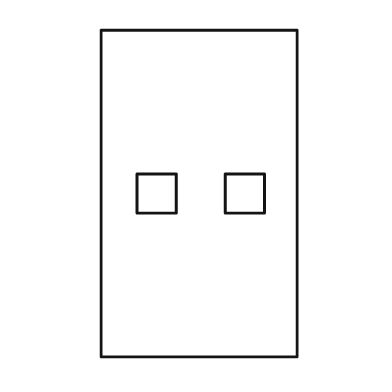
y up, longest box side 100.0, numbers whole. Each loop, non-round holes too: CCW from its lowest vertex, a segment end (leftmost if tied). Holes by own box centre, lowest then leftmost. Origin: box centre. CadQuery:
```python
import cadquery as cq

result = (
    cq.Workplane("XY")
    .moveTo(-30.0, -50.0)
    .lineTo(30.0, -50.0)
    .lineTo(30.0, 50.0)
    .lineTo(-30.0, 50.0)
    .close()
    .moveTo(-19.0, -6.0)
    .lineTo(-7.0, -6.0)
    .lineTo(-7.0, 6.0)
    .lineTo(-19.0, 6.0)
    .close()
    .moveTo(8.0, -6.0)
    .lineTo(20.0, -6.0)
    .lineTo(20.0, 6.0)
    .lineTo(8.0, 6.0)
    .close()
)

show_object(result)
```